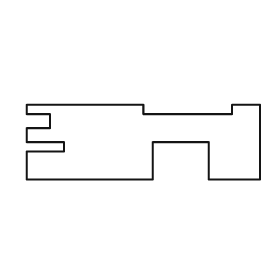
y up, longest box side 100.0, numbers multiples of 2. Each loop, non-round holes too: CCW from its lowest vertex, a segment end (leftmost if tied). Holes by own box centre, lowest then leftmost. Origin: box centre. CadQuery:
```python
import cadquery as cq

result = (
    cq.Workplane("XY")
    .moveTo(-50.0, -16.0)
    .lineTo(4.0, -16.0)
    .lineTo(4.0, 0.0)
    .lineTo(28.0, 0.0)
    .lineTo(28.0, -16.0)
    .lineTo(50.0, -16.0)
    .lineTo(50.0, 16.0)
    .lineTo(38.0, 16.0)
    .lineTo(38.0, 12.0)
    .lineTo(0.0, 12.0)
    .lineTo(0.0, 16.0)
    .lineTo(-50.0, 16.0)
    .lineTo(-50.0, 12.0)
    .lineTo(-40.0, 12.0)
    .lineTo(-40.0, 6.0)
    .lineTo(-50.0, 6.0)
    .lineTo(-50.0, 0.0)
    .lineTo(-34.0, 0.0)
    .lineTo(-34.0, -4.0)
    .lineTo(-50.0, -4.0)
    .close()
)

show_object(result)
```